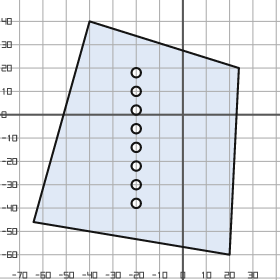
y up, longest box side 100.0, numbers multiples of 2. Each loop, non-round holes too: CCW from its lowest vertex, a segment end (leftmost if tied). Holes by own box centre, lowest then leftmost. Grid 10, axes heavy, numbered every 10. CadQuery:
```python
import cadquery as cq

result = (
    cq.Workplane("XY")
    .moveTo(20.0, -60.0)
    .lineTo(24.0, 20.0)
    .lineTo(-40.0, 40.0)
    .lineTo(-64.0, -46.0)
    .close()
    .moveTo(-20.0, -38.0)
    .circle(2.0)
    .moveTo(-20.0, -30.0)
    .circle(2.0)
    .moveTo(-20.0, -22.0)
    .circle(2.0)
    .moveTo(-20.0, -14.0)
    .circle(2.0)
    .moveTo(-20.0, -6.0)
    .circle(2.0)
    .moveTo(-20.0, 2.0)
    .circle(2.0)
    .moveTo(-20.0, 10.0)
    .circle(2.0)
    .moveTo(-20.0, 18.0)
    .circle(2.0)
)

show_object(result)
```